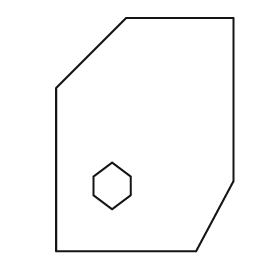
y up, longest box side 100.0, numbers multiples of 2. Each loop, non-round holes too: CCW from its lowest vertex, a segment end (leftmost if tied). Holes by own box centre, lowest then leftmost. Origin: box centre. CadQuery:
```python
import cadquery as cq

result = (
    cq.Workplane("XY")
    .moveTo(-38.0, -50.0)
    .lineTo(22.0, -50.0)
    .lineTo(38.0, -20.0)
    .lineTo(38.0, 50.0)
    .lineTo(-8.0, 50.0)
    .lineTo(-38.0, 20.0)
    .close()
    .moveTo(-14.0, -32.0)
    .lineTo(-6.0, -26.0)
    .lineTo(-6.0, -18.0)
    .lineTo(-14.0, -12.0)
    .lineTo(-22.0, -18.0)
    .lineTo(-22.0, -26.0)
    .close()
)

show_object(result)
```